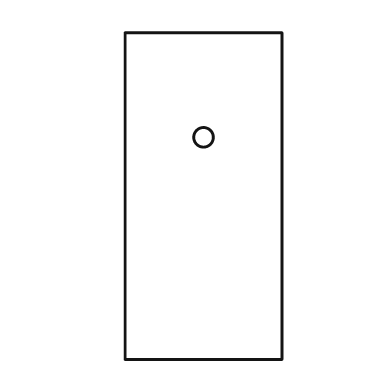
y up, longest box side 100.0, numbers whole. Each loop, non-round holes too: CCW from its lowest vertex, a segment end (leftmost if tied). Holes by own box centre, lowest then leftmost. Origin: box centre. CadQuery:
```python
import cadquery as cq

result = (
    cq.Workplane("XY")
    .moveTo(-24.0, -50.0)
    .lineTo(24.0, -50.0)
    .lineTo(24.0, 50.0)
    .lineTo(-24.0, 50.0)
    .close()
    .moveTo(0.0, 18.0)
    .circle(3.0)
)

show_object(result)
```